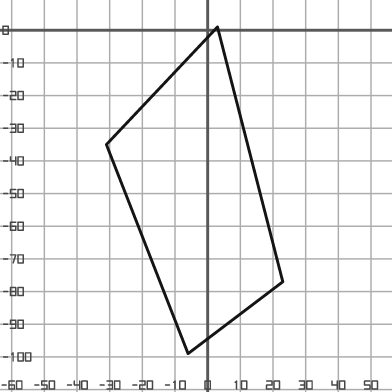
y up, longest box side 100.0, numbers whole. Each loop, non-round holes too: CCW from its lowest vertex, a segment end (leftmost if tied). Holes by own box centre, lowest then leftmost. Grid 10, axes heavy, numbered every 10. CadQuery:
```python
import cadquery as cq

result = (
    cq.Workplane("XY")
    .moveTo(-6.0, -99.0)
    .lineTo(23.0, -77.0)
    .lineTo(3.0, 1.0)
    .lineTo(-31.0, -35.0)
    .close()
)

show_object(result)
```